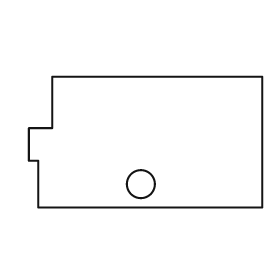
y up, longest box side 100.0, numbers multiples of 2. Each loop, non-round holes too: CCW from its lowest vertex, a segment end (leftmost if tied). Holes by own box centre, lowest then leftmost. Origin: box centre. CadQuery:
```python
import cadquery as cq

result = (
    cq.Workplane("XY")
    .moveTo(-46.0, -28.0)
    .lineTo(50.0, -28.0)
    .lineTo(50.0, 28.0)
    .lineTo(-40.0, 28.0)
    .lineTo(-40.0, 6.0)
    .lineTo(-50.0, 6.0)
    .lineTo(-50.0, -8.0)
    .lineTo(-46.0, -8.0)
    .close()
    .moveTo(-2.0, -18.0)
    .circle(6.0)
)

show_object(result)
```